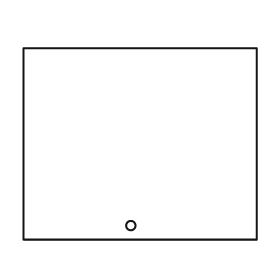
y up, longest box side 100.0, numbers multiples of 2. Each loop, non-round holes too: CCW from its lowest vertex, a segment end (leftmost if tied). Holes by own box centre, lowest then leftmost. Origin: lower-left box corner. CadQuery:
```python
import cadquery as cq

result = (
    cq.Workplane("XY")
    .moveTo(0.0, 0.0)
    .lineTo(100.0, 0.0)
    .lineTo(100.0, 82.0)
    .lineTo(0.0, 82.0)
    .close()
    .moveTo(46.0, 6.0)
    .circle(2.0)
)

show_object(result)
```